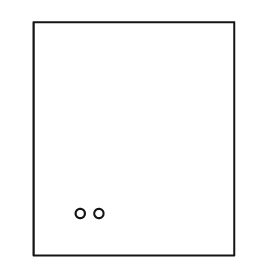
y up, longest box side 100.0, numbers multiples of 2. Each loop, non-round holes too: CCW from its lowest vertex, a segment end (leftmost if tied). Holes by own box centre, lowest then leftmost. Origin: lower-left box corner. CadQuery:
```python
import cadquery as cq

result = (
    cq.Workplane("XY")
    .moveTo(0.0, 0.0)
    .lineTo(86.0, 0.0)
    .lineTo(86.0, 100.0)
    .lineTo(0.0, 100.0)
    .close()
    .moveTo(20.0, 18.0)
    .circle(2.0)
    .moveTo(28.0, 18.0)
    .circle(2.0)
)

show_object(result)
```